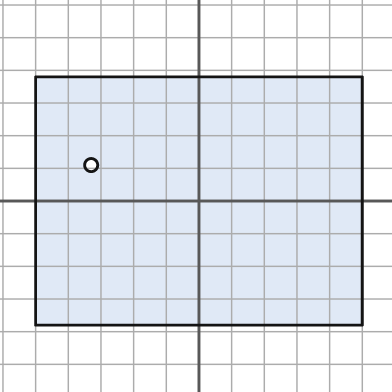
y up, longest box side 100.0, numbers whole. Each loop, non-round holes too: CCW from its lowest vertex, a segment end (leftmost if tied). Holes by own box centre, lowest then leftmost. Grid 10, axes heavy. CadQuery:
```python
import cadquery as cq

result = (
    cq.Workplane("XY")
    .moveTo(-50.0, -38.0)
    .lineTo(50.0, -38.0)
    .lineTo(50.0, 38.0)
    .lineTo(-50.0, 38.0)
    .close()
    .moveTo(-33.0, 11.0)
    .circle(2.0)
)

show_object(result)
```